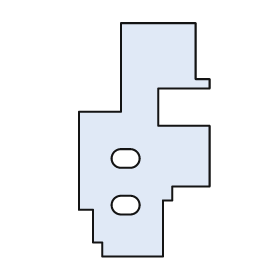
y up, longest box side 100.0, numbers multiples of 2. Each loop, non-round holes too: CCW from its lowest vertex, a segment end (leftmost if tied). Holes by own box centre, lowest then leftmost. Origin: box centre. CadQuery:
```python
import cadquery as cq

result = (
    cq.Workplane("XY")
    .moveTo(-18.0, -50.0)
    .lineTo(8.0, -50.0)
    .lineTo(8.0, -26.0)
    .lineTo(12.0, -26.0)
    .lineTo(12.0, -20.0)
    .lineTo(28.0, -20.0)
    .lineTo(28.0, 6.0)
    .lineTo(6.0, 6.0)
    .lineTo(6.0, 22.0)
    .lineTo(28.0, 22.0)
    .lineTo(28.0, 26.0)
    .lineTo(22.0, 26.0)
    .lineTo(22.0, 50.0)
    .lineTo(-10.0, 50.0)
    .lineTo(-10.0, 12.0)
    .lineTo(-28.0, 12.0)
    .lineTo(-28.0, -30.0)
    .lineTo(-22.0, -30.0)
    .lineTo(-22.0, -44.0)
    .lineTo(-18.0, -44.0)
    .close()
    .moveTo(-10.0, -32.0)
    .lineTo(-6.0, -32.0)
    .threePointArc((-2.0, -28.0), (-6.0, -24.0))
    .lineTo(-10.0, -24.0)
    .threePointArc((-14.0, -28.0), (-10.0, -32.0))
    .close()
    .moveTo(-10.0, -12.0)
    .lineTo(-6.0, -12.0)
    .threePointArc((-2.0, -8.0), (-6.0, -4.0))
    .lineTo(-10.0, -4.0)
    .threePointArc((-14.0, -8.0), (-10.0, -12.0))
    .close()
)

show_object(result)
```